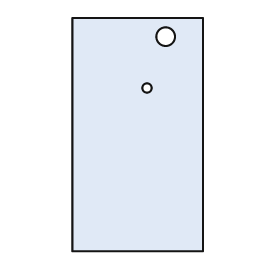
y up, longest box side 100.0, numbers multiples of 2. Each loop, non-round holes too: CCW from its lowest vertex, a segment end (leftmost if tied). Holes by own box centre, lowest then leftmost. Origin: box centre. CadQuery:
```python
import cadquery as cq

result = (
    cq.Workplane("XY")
    .moveTo(-28.0, -50.0)
    .lineTo(28.0, -50.0)
    .lineTo(28.0, 50.0)
    .lineTo(-28.0, 50.0)
    .close()
    .moveTo(4.0, 20.0)
    .circle(2.0)
    .moveTo(12.0, 42.0)
    .circle(4.0)
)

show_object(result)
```